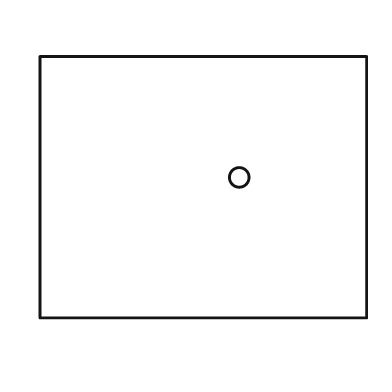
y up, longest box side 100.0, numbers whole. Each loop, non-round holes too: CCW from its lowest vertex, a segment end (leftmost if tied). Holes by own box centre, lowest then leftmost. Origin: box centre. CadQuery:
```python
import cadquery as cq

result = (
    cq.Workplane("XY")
    .moveTo(-50.0, -40.0)
    .lineTo(50.0, -40.0)
    .lineTo(50.0, 40.0)
    .lineTo(-50.0, 40.0)
    .close()
    .moveTo(11.0, 3.0)
    .circle(3.0)
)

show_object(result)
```